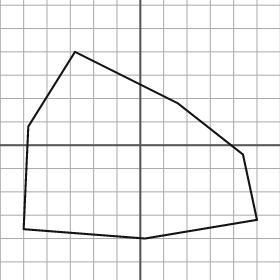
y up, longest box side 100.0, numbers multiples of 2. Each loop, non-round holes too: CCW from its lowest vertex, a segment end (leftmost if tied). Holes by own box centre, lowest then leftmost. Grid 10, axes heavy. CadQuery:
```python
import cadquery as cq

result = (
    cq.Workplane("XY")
    .moveTo(2.0, -40.0)
    .lineTo(50.0, -32.0)
    .lineTo(44.0, -4.0)
    .lineTo(16.0, 18.0)
    .lineTo(-28.0, 40.0)
    .lineTo(-48.0, 8.0)
    .lineTo(-50.0, -36.0)
    .close()
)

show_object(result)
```